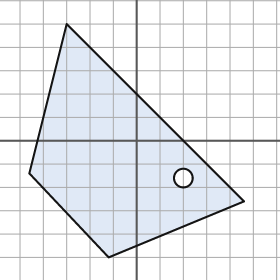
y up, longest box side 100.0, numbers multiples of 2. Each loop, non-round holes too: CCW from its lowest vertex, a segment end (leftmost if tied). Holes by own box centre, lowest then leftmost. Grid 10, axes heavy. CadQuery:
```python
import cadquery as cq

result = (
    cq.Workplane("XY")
    .moveTo(-12.0, -50.0)
    .lineTo(46.0, -26.0)
    .lineTo(-30.0, 50.0)
    .lineTo(-46.0, -14.0)
    .close()
    .moveTo(20.0, -16.0)
    .circle(4.0)
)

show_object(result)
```